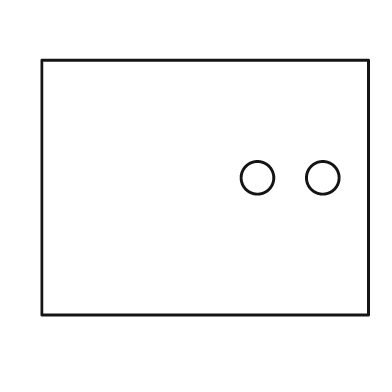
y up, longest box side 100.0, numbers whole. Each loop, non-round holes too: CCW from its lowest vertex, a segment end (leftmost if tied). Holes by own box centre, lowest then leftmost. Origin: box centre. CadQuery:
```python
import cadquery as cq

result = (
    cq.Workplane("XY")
    .moveTo(-50.0, -39.0)
    .lineTo(50.0, -39.0)
    .lineTo(50.0, 39.0)
    .lineTo(-50.0, 39.0)
    .close()
    .moveTo(16.0, 3.0)
    .circle(5.0)
    .moveTo(36.0, 3.0)
    .circle(5.0)
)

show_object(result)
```